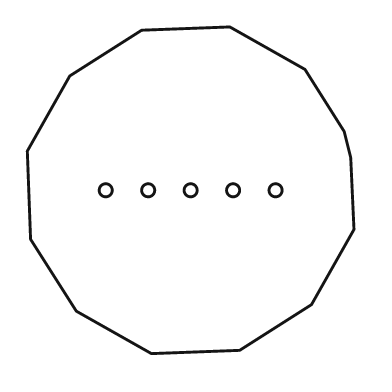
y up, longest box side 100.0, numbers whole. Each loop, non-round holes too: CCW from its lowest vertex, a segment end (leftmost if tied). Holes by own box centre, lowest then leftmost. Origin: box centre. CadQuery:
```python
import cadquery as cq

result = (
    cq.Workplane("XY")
    .moveTo(-12.0, -50.0)
    .lineTo(15.0, -49.0)
    .lineTo(37.0, -35.0)
    .lineTo(50.0, -12.0)
    .lineTo(49.0, 10.0)
    .lineTo(47.0, 18.0)
    .lineTo(35.0, 37.0)
    .lineTo(12.0, 50.0)
    .lineTo(-15.0, 49.0)
    .lineTo(-37.0, 35.0)
    .lineTo(-50.0, 12.0)
    .lineTo(-49.0, -15.0)
    .lineTo(-35.0, -37.0)
    .close()
    .moveTo(-26.0, 0.0)
    .circle(2.0)
    .moveTo(-13.0, 0.0)
    .circle(2.0)
    .moveTo(0.0, 0.0)
    .circle(2.0)
    .moveTo(13.0, 0.0)
    .circle(2.0)
    .moveTo(26.0, 0.0)
    .circle(2.0)
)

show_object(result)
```